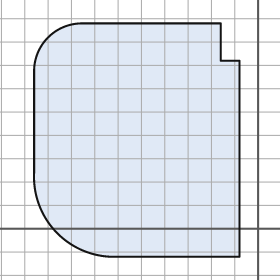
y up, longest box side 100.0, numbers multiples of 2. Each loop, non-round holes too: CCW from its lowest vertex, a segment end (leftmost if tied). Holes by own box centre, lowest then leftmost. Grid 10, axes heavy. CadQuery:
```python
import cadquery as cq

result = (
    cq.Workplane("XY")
    .moveTo(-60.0, -12.0)
    .lineTo(-8.0, -12.0)
    .lineTo(-8.0, 72.0)
    .lineTo(-16.0, 72.0)
    .lineTo(-16.0, 88.0)
    .lineTo(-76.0, 88.0)
    .threePointArc((-90.0, 82.0), (-96.0, 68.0))
    .lineTo(-96.0, 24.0)
    .threePointArc((-86.0, -2.0), (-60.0, -12.0))
    .close()
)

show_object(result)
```